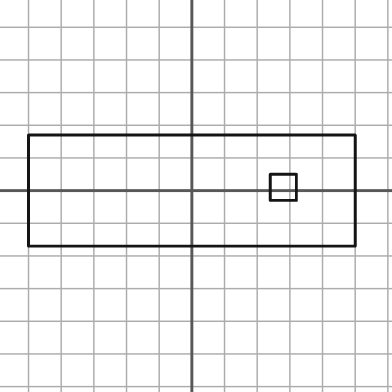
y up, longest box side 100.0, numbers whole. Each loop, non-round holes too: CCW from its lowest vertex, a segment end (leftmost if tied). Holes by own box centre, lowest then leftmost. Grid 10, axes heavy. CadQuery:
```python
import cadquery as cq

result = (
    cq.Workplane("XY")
    .moveTo(-50.0, -17.0)
    .lineTo(50.0, -17.0)
    .lineTo(50.0, 17.0)
    .lineTo(-50.0, 17.0)
    .close()
    .moveTo(24.0, -3.0)
    .lineTo(32.0, -3.0)
    .lineTo(32.0, 5.0)
    .lineTo(24.0, 5.0)
    .close()
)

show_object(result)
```